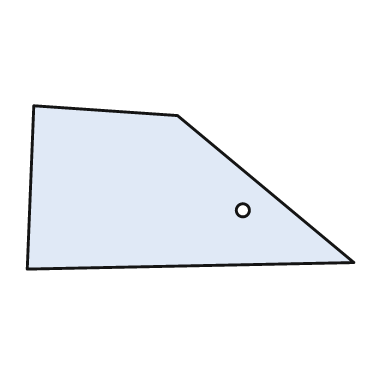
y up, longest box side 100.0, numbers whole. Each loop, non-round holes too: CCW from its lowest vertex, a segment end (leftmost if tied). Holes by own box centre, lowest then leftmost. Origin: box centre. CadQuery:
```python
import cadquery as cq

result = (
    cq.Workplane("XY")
    .moveTo(-50.0, -25.0)
    .lineTo(50.0, -23.0)
    .lineTo(-4.0, 22.0)
    .lineTo(-48.0, 25.0)
    .close()
    .moveTo(16.0, -7.0)
    .circle(2.0)
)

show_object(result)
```